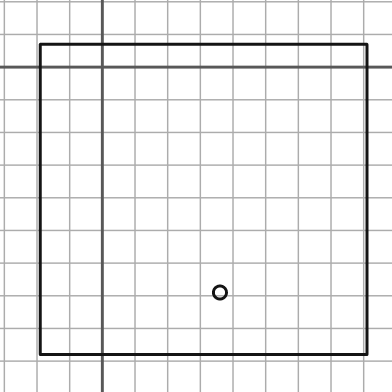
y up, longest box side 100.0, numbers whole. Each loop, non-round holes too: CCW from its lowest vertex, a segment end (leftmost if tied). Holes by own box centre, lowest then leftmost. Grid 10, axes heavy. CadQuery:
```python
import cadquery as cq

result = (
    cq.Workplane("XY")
    .moveTo(-19.0, -88.0)
    .lineTo(81.0, -88.0)
    .lineTo(81.0, 7.0)
    .lineTo(-19.0, 7.0)
    .close()
    .moveTo(36.0, -69.0)
    .circle(2.0)
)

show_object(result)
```